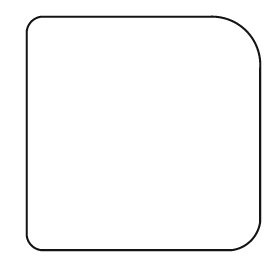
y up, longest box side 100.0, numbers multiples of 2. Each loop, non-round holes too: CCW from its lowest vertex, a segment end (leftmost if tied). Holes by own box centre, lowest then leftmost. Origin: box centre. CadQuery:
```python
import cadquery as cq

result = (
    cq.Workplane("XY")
    .moveTo(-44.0, -50.0)
    .lineTo(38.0, -50.0)
    .threePointArc((46.0, -46.0), (50.0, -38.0))
    .lineTo(50.0, 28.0)
    .threePointArc((44.0, 44.0), (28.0, 50.0))
    .lineTo(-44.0, 50.0)
    .threePointArc((-48.0, 48.0), (-50.0, 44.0))
    .lineTo(-50.0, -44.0)
    .threePointArc((-48.0, -48.0), (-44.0, -50.0))
    .close()
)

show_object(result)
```